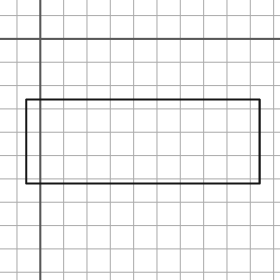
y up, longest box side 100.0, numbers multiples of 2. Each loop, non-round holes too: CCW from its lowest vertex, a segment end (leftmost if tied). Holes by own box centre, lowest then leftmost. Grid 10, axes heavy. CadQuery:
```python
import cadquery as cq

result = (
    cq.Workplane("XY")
    .moveTo(-6.0, -62.0)
    .lineTo(94.0, -62.0)
    .lineTo(94.0, -26.0)
    .lineTo(-6.0, -26.0)
    .close()
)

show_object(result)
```